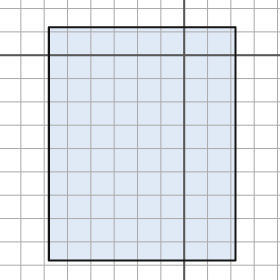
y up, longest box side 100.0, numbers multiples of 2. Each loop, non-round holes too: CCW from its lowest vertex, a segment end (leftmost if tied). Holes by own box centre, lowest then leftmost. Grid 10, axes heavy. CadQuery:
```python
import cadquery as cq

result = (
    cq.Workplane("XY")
    .moveTo(-58.0, -88.0)
    .lineTo(22.0, -88.0)
    .lineTo(22.0, 12.0)
    .lineTo(-58.0, 12.0)
    .close()
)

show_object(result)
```